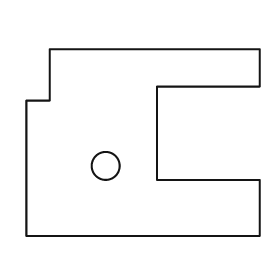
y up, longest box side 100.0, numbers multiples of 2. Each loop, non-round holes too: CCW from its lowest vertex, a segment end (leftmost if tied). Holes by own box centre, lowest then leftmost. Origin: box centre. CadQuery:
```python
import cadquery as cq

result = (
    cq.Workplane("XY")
    .moveTo(-50.0, -40.0)
    .lineTo(50.0, -40.0)
    .lineTo(50.0, -16.0)
    .lineTo(6.0, -16.0)
    .lineTo(6.0, 24.0)
    .lineTo(50.0, 24.0)
    .lineTo(50.0, 40.0)
    .lineTo(-40.0, 40.0)
    .lineTo(-40.0, 18.0)
    .lineTo(-50.0, 18.0)
    .close()
    .moveTo(-16.0, -10.0)
    .circle(6.0)
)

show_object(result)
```